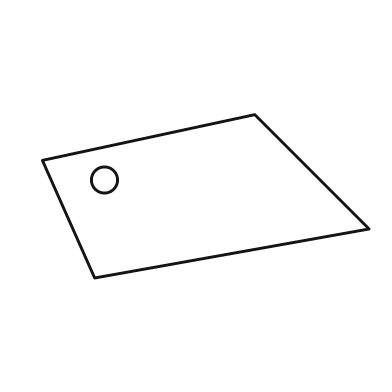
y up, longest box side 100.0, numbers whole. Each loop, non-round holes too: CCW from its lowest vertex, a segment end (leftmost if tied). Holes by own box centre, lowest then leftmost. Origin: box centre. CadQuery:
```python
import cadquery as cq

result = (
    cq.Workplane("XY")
    .moveTo(-34.0, -25.0)
    .lineTo(50.0, -10.0)
    .lineTo(15.0, 25.0)
    .lineTo(-50.0, 11.0)
    .close()
    .moveTo(-31.0, 5.0)
    .circle(4.0)
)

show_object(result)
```